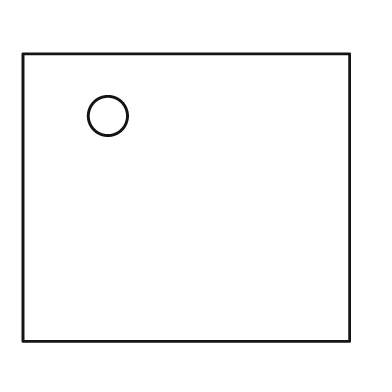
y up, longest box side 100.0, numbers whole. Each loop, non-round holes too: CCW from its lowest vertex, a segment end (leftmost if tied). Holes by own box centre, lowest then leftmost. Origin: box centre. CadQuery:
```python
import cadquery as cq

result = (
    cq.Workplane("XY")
    .moveTo(-50.0, -44.0)
    .lineTo(50.0, -44.0)
    .lineTo(50.0, 44.0)
    .lineTo(-50.0, 44.0)
    .close()
    .moveTo(-24.0, 25.0)
    .circle(6.0)
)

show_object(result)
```